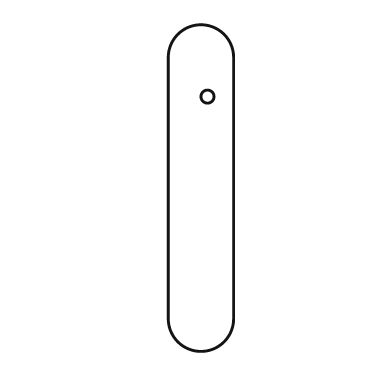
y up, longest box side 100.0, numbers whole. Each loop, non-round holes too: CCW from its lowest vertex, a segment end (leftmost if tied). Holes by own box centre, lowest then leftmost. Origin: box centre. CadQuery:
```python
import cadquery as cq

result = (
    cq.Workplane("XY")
    .moveTo(-10.0, -40.0)
    .threePointArc((0.0, -50.0), (10.0, -40.0))
    .lineTo(10.0, 40.0)
    .threePointArc((0.0, 50.0), (-10.0, 40.0))
    .close()
    .moveTo(2.0, 28.0)
    .circle(2.0)
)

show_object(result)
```